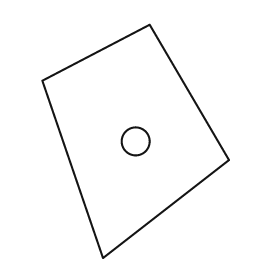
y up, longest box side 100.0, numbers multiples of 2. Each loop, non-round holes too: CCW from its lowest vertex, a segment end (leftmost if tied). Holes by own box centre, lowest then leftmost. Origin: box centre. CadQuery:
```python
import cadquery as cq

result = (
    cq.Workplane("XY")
    .moveTo(-14.0, -50.0)
    .lineTo(40.0, -8.0)
    .lineTo(6.0, 50.0)
    .lineTo(-40.0, 26.0)
    .close()
    .moveTo(0.0, 0.0)
    .circle(6.0)
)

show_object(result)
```